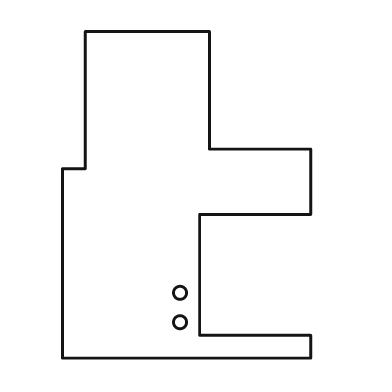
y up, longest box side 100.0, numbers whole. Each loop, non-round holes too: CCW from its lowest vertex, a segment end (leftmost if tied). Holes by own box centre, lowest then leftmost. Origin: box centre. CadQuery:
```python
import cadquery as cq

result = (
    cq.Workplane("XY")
    .moveTo(-38.0, -50.0)
    .lineTo(38.0, -50.0)
    .lineTo(38.0, -43.0)
    .lineTo(4.0, -43.0)
    .lineTo(4.0, -6.0)
    .lineTo(38.0, -6.0)
    .lineTo(38.0, 14.0)
    .lineTo(7.0, 14.0)
    .lineTo(7.0, 50.0)
    .lineTo(-31.0, 50.0)
    .lineTo(-31.0, 8.0)
    .lineTo(-38.0, 8.0)
    .close()
    .moveTo(-2.0, -39.0)
    .circle(2.0)
    .moveTo(-2.0, -30.0)
    .circle(2.0)
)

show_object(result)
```